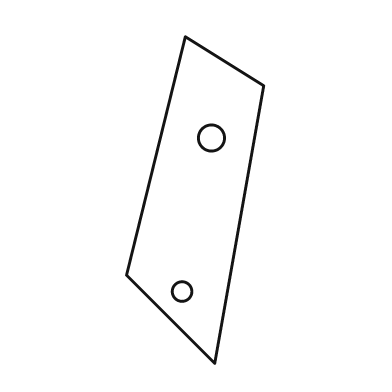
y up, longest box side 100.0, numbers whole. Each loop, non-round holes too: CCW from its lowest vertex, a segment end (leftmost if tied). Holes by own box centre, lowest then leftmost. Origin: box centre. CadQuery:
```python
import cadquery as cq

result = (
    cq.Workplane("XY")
    .moveTo(6.0, -50.0)
    .lineTo(21.0, 35.0)
    .lineTo(-3.0, 50.0)
    .lineTo(-21.0, -23.0)
    .close()
    .moveTo(-4.0, -28.0)
    .circle(3.0)
    .moveTo(5.0, 19.0)
    .circle(4.0)
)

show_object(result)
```